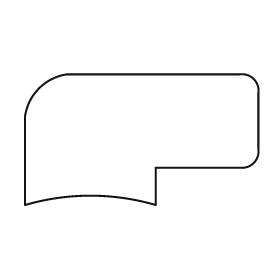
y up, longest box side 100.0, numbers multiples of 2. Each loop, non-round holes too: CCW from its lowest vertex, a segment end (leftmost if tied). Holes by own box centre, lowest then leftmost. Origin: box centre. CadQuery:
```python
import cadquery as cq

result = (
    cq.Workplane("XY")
    .moveTo(-50.0, -28.0)
    .threePointArc((-22.0, -24.0), (6.0, -28.0))
    .lineTo(6.0, -12.0)
    .lineTo(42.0, -12.0)
    .threePointArc((48.0, -10.0), (50.0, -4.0))
    .lineTo(50.0, 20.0)
    .threePointArc((48.0, 26.0), (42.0, 28.0))
    .lineTo(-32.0, 28.0)
    .threePointArc((-44.0, 22.0), (-50.0, 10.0))
    .close()
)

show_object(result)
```